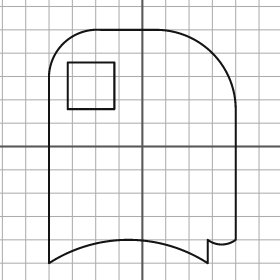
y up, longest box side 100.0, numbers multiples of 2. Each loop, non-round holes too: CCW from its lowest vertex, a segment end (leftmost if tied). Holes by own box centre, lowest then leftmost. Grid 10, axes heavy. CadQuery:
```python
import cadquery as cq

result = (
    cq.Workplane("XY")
    .moveTo(-40.0, -50.0)
    .threePointArc((-6.0, -40.0), (28.0, -50.0))
    .lineTo(28.0, -40.0)
    .threePointArc((34.0, -42.0), (40.0, -40.0))
    .lineTo(40.0, 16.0)
    .threePointArc((30.0, 40.0), (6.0, 50.0))
    .lineTo(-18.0, 50.0)
    .threePointArc((-34.0, 44.0), (-40.0, 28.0))
    .close()
    .moveTo(-32.0, 16.0)
    .lineTo(-12.0, 16.0)
    .lineTo(-12.0, 36.0)
    .lineTo(-32.0, 36.0)
    .close()
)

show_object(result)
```